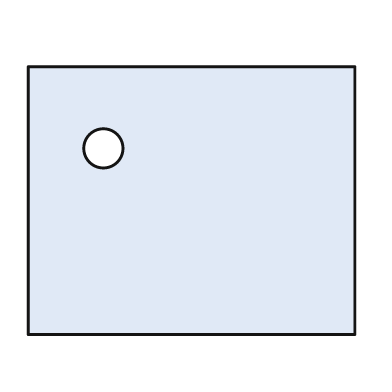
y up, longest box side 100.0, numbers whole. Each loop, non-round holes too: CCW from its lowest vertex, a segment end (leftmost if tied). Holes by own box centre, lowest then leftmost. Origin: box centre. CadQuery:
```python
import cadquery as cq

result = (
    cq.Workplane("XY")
    .moveTo(-50.0, -41.0)
    .lineTo(50.0, -41.0)
    .lineTo(50.0, 41.0)
    .lineTo(-50.0, 41.0)
    .close()
    .moveTo(-27.0, 16.0)
    .circle(6.0)
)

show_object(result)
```